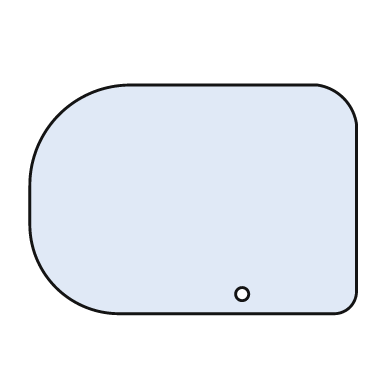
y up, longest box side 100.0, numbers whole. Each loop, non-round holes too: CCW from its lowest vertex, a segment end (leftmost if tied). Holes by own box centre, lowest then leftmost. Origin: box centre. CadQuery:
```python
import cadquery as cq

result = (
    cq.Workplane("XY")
    .moveTo(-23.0, -35.0)
    .lineTo(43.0, -35.0)
    .threePointArc((48.0, -33.0), (50.0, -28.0))
    .lineTo(50.0, 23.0)
    .threePointArc((46.0, 31.0), (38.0, 35.0))
    .lineTo(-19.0, 35.0)
    .threePointArc((-41.0, 26.0), (-50.0, 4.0))
    .lineTo(-50.0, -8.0)
    .threePointArc((-42.0, -27.0), (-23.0, -35.0))
    .close()
    .moveTo(15.0, -29.0)
    .circle(2.0)
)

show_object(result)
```